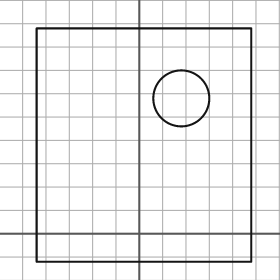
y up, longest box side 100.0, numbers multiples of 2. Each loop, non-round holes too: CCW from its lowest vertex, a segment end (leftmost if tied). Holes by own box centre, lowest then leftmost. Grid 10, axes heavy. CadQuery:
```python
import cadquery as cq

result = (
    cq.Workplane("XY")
    .moveTo(-44.0, -12.0)
    .lineTo(48.0, -12.0)
    .lineTo(48.0, 88.0)
    .lineTo(-44.0, 88.0)
    .close()
    .moveTo(18.0, 58.0)
    .circle(12.0)
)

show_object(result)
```